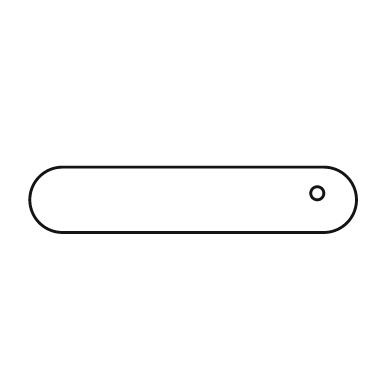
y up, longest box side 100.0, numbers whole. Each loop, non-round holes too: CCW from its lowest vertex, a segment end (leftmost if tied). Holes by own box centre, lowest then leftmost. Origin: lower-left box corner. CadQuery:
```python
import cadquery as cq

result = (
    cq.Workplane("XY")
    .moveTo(10.0, 0.0)
    .lineTo(90.0, 0.0)
    .threePointArc((100.0, 10.0), (90.0, 20.0))
    .lineTo(10.0, 20.0)
    .threePointArc((0.0, 10.0), (10.0, 0.0))
    .close()
    .moveTo(88.0, 12.0)
    .circle(2.0)
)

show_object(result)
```